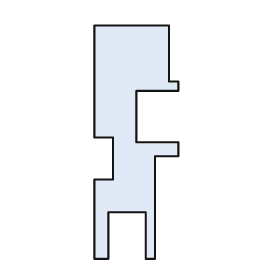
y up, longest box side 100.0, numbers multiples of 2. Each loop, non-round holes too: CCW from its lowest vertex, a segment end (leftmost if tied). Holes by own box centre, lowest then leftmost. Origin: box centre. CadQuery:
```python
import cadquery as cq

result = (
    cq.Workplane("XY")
    .moveTo(-18.0, -50.0)
    .lineTo(-12.0, -50.0)
    .lineTo(-12.0, -30.0)
    .lineTo(4.0, -30.0)
    .lineTo(4.0, -50.0)
    .lineTo(8.0, -50.0)
    .lineTo(8.0, -6.0)
    .lineTo(18.0, -6.0)
    .lineTo(18.0, 0.0)
    .lineTo(0.0, 0.0)
    .lineTo(0.0, 22.0)
    .lineTo(18.0, 22.0)
    .lineTo(18.0, 26.0)
    .lineTo(14.0, 26.0)
    .lineTo(14.0, 50.0)
    .lineTo(-18.0, 50.0)
    .lineTo(-18.0, 2.0)
    .lineTo(-10.0, 2.0)
    .lineTo(-10.0, -16.0)
    .lineTo(-18.0, -16.0)
    .close()
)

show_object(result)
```